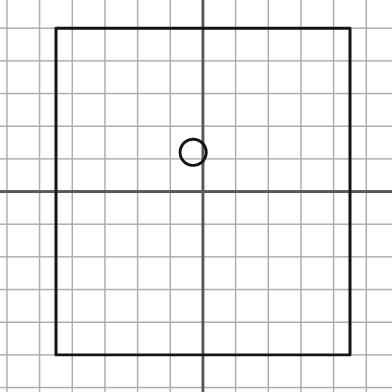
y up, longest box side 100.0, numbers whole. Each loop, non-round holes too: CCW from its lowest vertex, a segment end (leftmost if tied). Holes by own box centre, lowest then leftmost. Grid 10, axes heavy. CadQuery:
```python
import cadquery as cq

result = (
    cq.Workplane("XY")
    .moveTo(-45.0, -50.0)
    .lineTo(45.0, -50.0)
    .lineTo(45.0, 50.0)
    .lineTo(-45.0, 50.0)
    .close()
    .moveTo(-3.0, 12.0)
    .circle(4.0)
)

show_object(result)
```